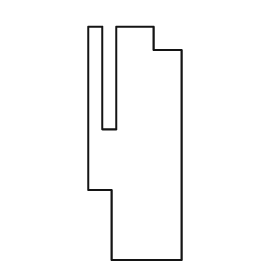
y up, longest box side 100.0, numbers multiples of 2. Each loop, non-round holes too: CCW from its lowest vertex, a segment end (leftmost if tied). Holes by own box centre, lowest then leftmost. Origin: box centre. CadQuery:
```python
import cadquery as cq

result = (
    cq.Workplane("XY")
    .moveTo(-10.0, -50.0)
    .lineTo(20.0, -50.0)
    .lineTo(20.0, 40.0)
    .lineTo(8.0, 40.0)
    .lineTo(8.0, 50.0)
    .lineTo(-8.0, 50.0)
    .lineTo(-8.0, 6.0)
    .lineTo(-14.0, 6.0)
    .lineTo(-14.0, 50.0)
    .lineTo(-20.0, 50.0)
    .lineTo(-20.0, -20.0)
    .lineTo(-10.0, -20.0)
    .close()
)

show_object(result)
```